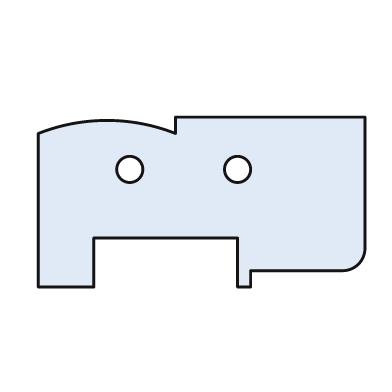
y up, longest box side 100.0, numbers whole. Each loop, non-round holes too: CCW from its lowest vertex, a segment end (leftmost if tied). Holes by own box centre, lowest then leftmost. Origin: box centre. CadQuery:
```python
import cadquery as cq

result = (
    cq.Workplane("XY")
    .moveTo(-50.0, -26.0)
    .lineTo(-33.0, -26.0)
    .lineTo(-33.0, -11.0)
    .lineTo(11.0, -11.0)
    .lineTo(11.0, -26.0)
    .lineTo(15.0, -26.0)
    .lineTo(15.0, -21.0)
    .lineTo(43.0, -21.0)
    .threePointArc((48.0, -19.0), (50.0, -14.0))
    .lineTo(50.0, 26.0)
    .lineTo(-8.0, 26.0)
    .lineTo(-8.0, 21.0)
    .threePointArc((-29.0, 25.0), (-50.0, 21.0))
    .close()
    .moveTo(-22.0, 10.0)
    .circle(4.0)
    .moveTo(11.0, 10.0)
    .circle(4.0)
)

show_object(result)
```